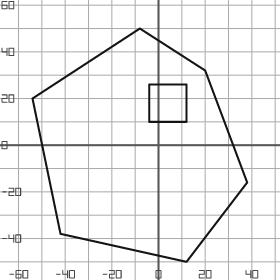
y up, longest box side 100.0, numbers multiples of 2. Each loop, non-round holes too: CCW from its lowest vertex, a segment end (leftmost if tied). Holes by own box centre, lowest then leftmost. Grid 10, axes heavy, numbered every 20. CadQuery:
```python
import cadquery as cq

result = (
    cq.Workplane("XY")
    .moveTo(12.0, -50.0)
    .lineTo(38.0, -16.0)
    .lineTo(20.0, 32.0)
    .lineTo(-8.0, 50.0)
    .lineTo(-54.0, 20.0)
    .lineTo(-42.0, -38.0)
    .close()
    .moveTo(-4.0, 10.0)
    .lineTo(12.0, 10.0)
    .lineTo(12.0, 26.0)
    .lineTo(-4.0, 26.0)
    .close()
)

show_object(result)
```